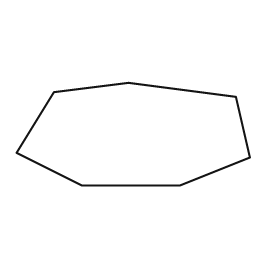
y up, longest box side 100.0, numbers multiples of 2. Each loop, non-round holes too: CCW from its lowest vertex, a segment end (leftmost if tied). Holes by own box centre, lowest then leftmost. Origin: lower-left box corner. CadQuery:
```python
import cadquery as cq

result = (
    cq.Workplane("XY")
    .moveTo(28.0, 0.0)
    .lineTo(70.0, 0.0)
    .lineTo(100.0, 12.0)
    .lineTo(94.0, 38.0)
    .lineTo(48.0, 44.0)
    .lineTo(16.0, 40.0)
    .lineTo(0.0, 14.0)
    .close()
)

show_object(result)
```